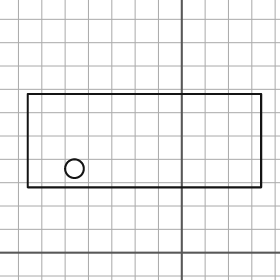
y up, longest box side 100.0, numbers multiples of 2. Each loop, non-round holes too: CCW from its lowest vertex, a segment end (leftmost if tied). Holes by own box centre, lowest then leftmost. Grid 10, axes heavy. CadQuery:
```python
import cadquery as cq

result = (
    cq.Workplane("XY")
    .moveTo(-66.0, 28.0)
    .lineTo(34.0, 28.0)
    .lineTo(34.0, 68.0)
    .lineTo(-66.0, 68.0)
    .close()
    .moveTo(-46.0, 36.0)
    .circle(4.0)
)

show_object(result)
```